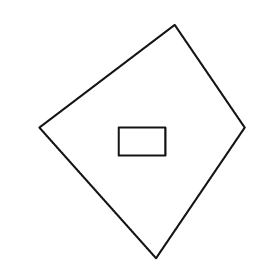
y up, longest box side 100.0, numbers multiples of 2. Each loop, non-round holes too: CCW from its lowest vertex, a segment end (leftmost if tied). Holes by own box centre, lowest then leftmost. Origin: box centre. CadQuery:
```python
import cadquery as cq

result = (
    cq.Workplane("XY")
    .moveTo(6.0, -50.0)
    .lineTo(44.0, 6.0)
    .lineTo(14.0, 50.0)
    .lineTo(-44.0, 6.0)
    .close()
    .moveTo(-10.0, -6.0)
    .lineTo(10.0, -6.0)
    .lineTo(10.0, 6.0)
    .lineTo(-10.0, 6.0)
    .close()
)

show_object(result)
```